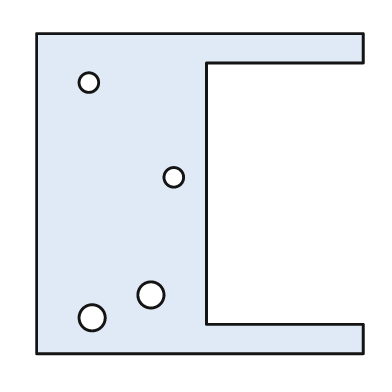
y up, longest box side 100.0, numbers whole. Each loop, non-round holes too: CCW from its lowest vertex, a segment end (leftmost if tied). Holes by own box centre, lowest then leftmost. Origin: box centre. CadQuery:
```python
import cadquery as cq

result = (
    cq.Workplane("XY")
    .moveTo(-50.0, -49.0)
    .lineTo(50.0, -49.0)
    .lineTo(50.0, -40.0)
    .lineTo(2.0, -40.0)
    .lineTo(2.0, 40.0)
    .lineTo(50.0, 40.0)
    .lineTo(50.0, 49.0)
    .lineTo(-50.0, 49.0)
    .close()
    .moveTo(-33.0, -38.0)
    .circle(4.0)
    .moveTo(-15.0, -31.0)
    .circle(4.0)
    .moveTo(-8.0, 5.0)
    .circle(3.0)
    .moveTo(-34.0, 34.0)
    .circle(3.0)
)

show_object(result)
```